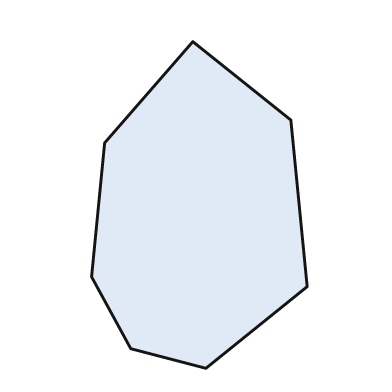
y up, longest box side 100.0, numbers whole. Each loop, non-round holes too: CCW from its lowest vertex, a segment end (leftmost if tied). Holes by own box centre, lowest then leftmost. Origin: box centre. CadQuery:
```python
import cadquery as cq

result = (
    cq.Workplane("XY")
    .moveTo(2.0, -50.0)
    .lineTo(33.0, -25.0)
    .lineTo(28.0, 26.0)
    .lineTo(-2.0, 50.0)
    .lineTo(-29.0, 19.0)
    .lineTo(-33.0, -22.0)
    .lineTo(-21.0, -44.0)
    .close()
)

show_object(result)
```